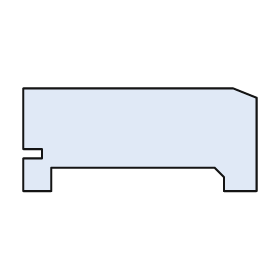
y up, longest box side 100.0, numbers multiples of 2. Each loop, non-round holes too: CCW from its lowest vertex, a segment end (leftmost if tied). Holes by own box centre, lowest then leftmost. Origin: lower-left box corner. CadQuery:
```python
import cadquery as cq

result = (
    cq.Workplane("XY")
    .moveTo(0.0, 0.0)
    .lineTo(12.0, 0.0)
    .lineTo(12.0, 10.0)
    .lineTo(82.0, 10.0)
    .lineTo(86.0, 6.0)
    .lineTo(86.0, 0.0)
    .lineTo(100.0, 0.0)
    .lineTo(100.0, 40.0)
    .lineTo(90.0, 44.0)
    .lineTo(0.0, 44.0)
    .lineTo(0.0, 18.0)
    .lineTo(8.0, 18.0)
    .lineTo(8.0, 14.0)
    .lineTo(0.0, 14.0)
    .close()
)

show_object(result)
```